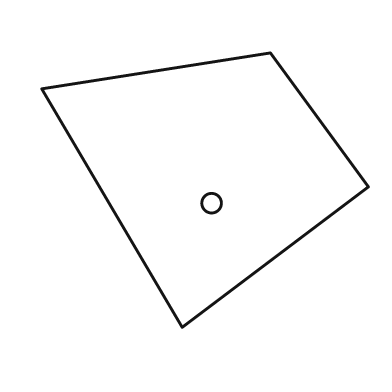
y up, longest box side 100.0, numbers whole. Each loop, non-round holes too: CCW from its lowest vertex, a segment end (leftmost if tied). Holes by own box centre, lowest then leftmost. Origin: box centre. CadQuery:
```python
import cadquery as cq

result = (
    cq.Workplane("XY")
    .moveTo(-7.0, -42.0)
    .lineTo(50.0, 1.0)
    .lineTo(20.0, 42.0)
    .lineTo(-50.0, 31.0)
    .close()
    .moveTo(2.0, -4.0)
    .circle(3.0)
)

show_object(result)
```